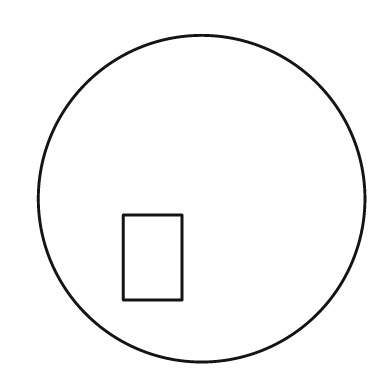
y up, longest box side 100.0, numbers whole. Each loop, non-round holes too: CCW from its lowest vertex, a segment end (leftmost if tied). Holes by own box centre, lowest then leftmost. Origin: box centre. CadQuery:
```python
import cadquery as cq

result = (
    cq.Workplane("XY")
    .moveTo(0.0, 0.0)
    .circle(50.0)
    .moveTo(-24.0, -31.0)
    .lineTo(-6.0, -31.0)
    .lineTo(-6.0, -5.0)
    .lineTo(-24.0, -5.0)
    .close()
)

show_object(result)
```